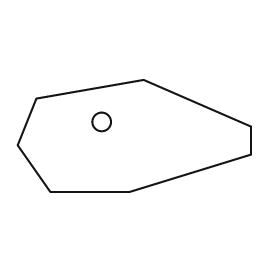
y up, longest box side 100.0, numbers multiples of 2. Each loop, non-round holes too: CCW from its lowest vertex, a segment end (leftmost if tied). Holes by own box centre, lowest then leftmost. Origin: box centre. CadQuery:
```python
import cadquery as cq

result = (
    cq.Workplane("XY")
    .moveTo(-36.0, -24.0)
    .lineTo(-2.0, -24.0)
    .lineTo(50.0, -8.0)
    .lineTo(50.0, 4.0)
    .lineTo(4.0, 24.0)
    .lineTo(-42.0, 16.0)
    .lineTo(-50.0, -4.0)
    .close()
    .moveTo(-14.0, 6.0)
    .circle(4.0)
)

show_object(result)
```